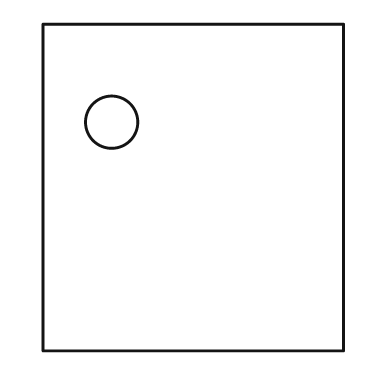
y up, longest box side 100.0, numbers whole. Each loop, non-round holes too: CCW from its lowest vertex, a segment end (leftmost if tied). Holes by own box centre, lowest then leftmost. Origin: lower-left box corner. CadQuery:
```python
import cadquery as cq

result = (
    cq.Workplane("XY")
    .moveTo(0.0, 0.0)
    .lineTo(92.0, 0.0)
    .lineTo(92.0, 100.0)
    .lineTo(0.0, 100.0)
    .close()
    .moveTo(21.0, 70.0)
    .circle(8.0)
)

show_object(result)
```